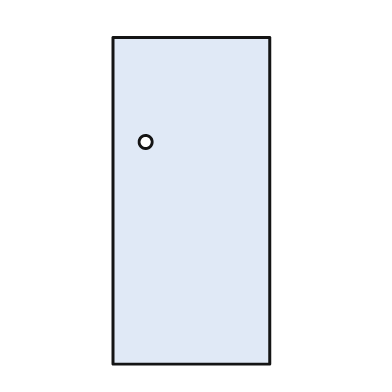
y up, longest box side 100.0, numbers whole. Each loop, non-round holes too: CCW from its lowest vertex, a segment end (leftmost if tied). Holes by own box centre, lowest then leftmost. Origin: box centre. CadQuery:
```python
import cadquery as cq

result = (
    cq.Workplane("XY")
    .moveTo(-24.0, -50.0)
    .lineTo(24.0, -50.0)
    .lineTo(24.0, 50.0)
    .lineTo(-24.0, 50.0)
    .close()
    .moveTo(-14.0, 18.0)
    .circle(2.0)
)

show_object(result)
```